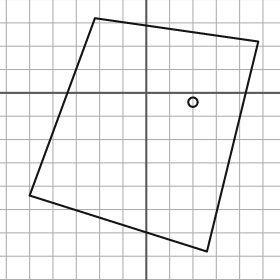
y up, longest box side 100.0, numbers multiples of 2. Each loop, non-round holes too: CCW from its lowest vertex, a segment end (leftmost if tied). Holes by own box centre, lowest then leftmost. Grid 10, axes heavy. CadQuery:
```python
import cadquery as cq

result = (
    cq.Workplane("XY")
    .moveTo(26.0, -68.0)
    .lineTo(48.0, 22.0)
    .lineTo(-22.0, 32.0)
    .lineTo(-50.0, -44.0)
    .close()
    .moveTo(20.0, -4.0)
    .circle(2.0)
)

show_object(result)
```